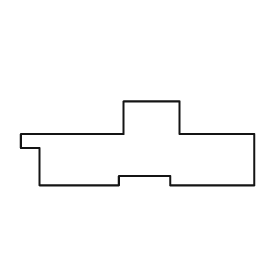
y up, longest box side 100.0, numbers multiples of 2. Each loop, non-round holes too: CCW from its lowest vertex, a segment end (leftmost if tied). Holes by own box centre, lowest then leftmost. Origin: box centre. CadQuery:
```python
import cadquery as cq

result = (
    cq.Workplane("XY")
    .moveTo(-42.0, -18.0)
    .lineTo(-8.0, -18.0)
    .lineTo(-8.0, -14.0)
    .lineTo(14.0, -14.0)
    .lineTo(14.0, -18.0)
    .lineTo(50.0, -18.0)
    .lineTo(50.0, 4.0)
    .lineTo(18.0, 4.0)
    .lineTo(18.0, 18.0)
    .lineTo(-6.0, 18.0)
    .lineTo(-6.0, 4.0)
    .lineTo(-50.0, 4.0)
    .lineTo(-50.0, -2.0)
    .lineTo(-42.0, -2.0)
    .close()
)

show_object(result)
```